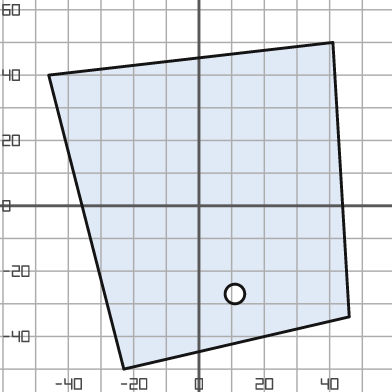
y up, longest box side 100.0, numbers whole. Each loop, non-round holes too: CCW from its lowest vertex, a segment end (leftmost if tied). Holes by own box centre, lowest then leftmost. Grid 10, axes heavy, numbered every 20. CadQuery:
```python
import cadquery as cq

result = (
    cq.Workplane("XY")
    .moveTo(-23.0, -50.0)
    .lineTo(46.0, -34.0)
    .lineTo(41.0, 50.0)
    .lineTo(-46.0, 40.0)
    .close()
    .moveTo(11.0, -27.0)
    .circle(3.0)
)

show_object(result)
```